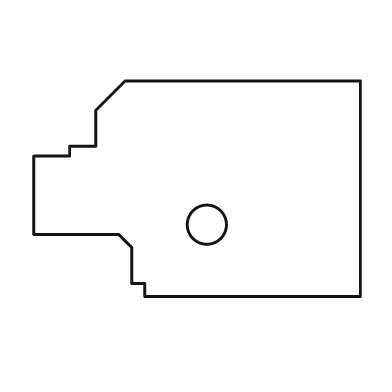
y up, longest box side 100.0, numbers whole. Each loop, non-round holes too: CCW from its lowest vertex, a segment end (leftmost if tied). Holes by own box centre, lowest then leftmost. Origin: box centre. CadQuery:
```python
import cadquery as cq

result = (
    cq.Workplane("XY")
    .moveTo(-16.0, -33.0)
    .lineTo(50.0, -33.0)
    .lineTo(50.0, 33.0)
    .lineTo(-22.0, 33.0)
    .lineTo(-31.0, 24.0)
    .lineTo(-31.0, 13.0)
    .lineTo(-39.0, 13.0)
    .lineTo(-39.0, 10.0)
    .lineTo(-50.0, 10.0)
    .lineTo(-50.0, -14.0)
    .lineTo(-24.0, -14.0)
    .lineTo(-20.0, -18.0)
    .lineTo(-20.0, -29.0)
    .lineTo(-16.0, -29.0)
    .close()
    .moveTo(3.0, -11.0)
    .circle(6.0)
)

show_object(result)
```